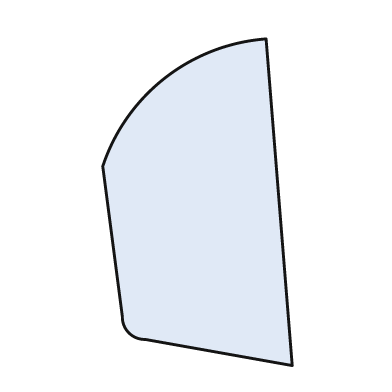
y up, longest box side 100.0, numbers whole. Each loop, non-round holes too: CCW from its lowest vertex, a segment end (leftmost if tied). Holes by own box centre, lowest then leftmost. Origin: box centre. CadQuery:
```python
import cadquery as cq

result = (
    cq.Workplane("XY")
    .moveTo(29.0, -50.0)
    .lineTo(21.0, 50.0)
    .threePointArc((-10.0, 38.0), (-29.0, 11.0))
    .lineTo(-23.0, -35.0)
    .threePointArc((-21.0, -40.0), (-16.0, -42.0))
    .close()
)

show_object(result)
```